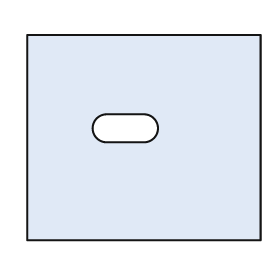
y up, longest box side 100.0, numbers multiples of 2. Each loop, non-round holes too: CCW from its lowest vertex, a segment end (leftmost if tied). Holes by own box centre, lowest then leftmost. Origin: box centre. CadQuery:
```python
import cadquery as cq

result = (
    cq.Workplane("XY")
    .moveTo(-50.0, -44.0)
    .lineTo(50.0, -44.0)
    .lineTo(50.0, 44.0)
    .lineTo(-50.0, 44.0)
    .close()
    .moveTo(-16.0, -2.0)
    .lineTo(0.0, -2.0)
    .threePointArc((6.0, 4.0), (0.0, 10.0))
    .lineTo(-16.0, 10.0)
    .threePointArc((-22.0, 4.0), (-16.0, -2.0))
    .close()
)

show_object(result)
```